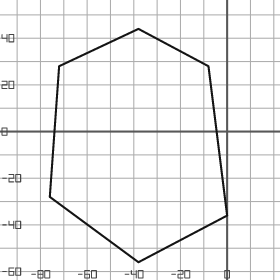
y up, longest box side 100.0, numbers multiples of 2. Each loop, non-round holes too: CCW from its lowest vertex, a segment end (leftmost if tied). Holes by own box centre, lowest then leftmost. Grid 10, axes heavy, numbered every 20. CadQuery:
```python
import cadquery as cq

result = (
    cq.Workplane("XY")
    .moveTo(-38.0, -56.0)
    .lineTo(0.0, -36.0)
    .lineTo(-8.0, 28.0)
    .lineTo(-38.0, 44.0)
    .lineTo(-72.0, 28.0)
    .lineTo(-76.0, -28.0)
    .close()
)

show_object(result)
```